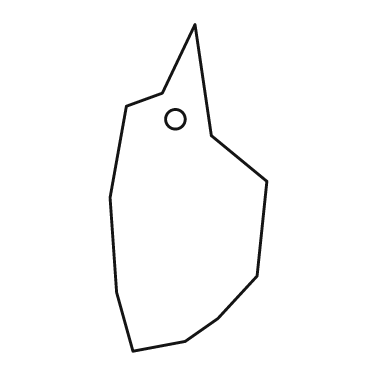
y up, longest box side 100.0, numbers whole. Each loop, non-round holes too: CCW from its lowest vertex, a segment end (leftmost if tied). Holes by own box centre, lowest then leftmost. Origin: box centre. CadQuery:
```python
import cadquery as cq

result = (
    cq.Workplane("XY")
    .moveTo(-17.0, -50.0)
    .lineTo(-1.0, -47.0)
    .lineTo(9.0, -40.0)
    .lineTo(21.0, -27.0)
    .lineTo(24.0, 2.0)
    .lineTo(7.0, 16.0)
    .lineTo(2.0, 50.0)
    .lineTo(-8.0, 29.0)
    .lineTo(-19.0, 25.0)
    .lineTo(-24.0, -3.0)
    .lineTo(-22.0, -32.0)
    .close()
    .moveTo(-4.0, 21.0)
    .circle(3.0)
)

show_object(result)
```